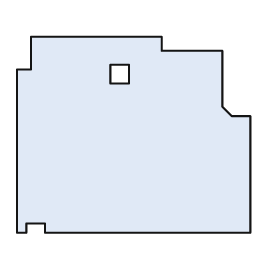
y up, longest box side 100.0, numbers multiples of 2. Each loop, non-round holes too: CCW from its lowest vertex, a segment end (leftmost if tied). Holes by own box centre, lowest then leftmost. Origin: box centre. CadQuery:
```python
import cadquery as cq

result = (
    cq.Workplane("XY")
    .moveTo(-50.0, -42.0)
    .lineTo(-46.0, -42.0)
    .lineTo(-46.0, -38.0)
    .lineTo(-38.0, -38.0)
    .lineTo(-38.0, -42.0)
    .lineTo(50.0, -42.0)
    .lineTo(50.0, 8.0)
    .lineTo(42.0, 8.0)
    .lineTo(38.0, 12.0)
    .lineTo(38.0, 36.0)
    .lineTo(12.0, 36.0)
    .lineTo(12.0, 42.0)
    .lineTo(-44.0, 42.0)
    .lineTo(-44.0, 28.0)
    .lineTo(-50.0, 28.0)
    .close()
    .moveTo(-10.0, 22.0)
    .lineTo(-2.0, 22.0)
    .lineTo(-2.0, 30.0)
    .lineTo(-10.0, 30.0)
    .close()
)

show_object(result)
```